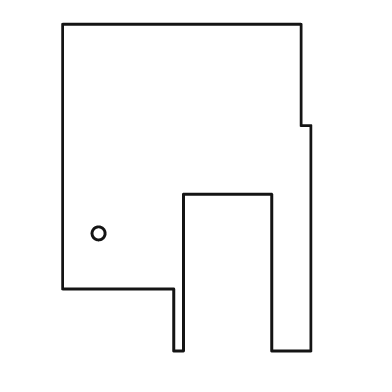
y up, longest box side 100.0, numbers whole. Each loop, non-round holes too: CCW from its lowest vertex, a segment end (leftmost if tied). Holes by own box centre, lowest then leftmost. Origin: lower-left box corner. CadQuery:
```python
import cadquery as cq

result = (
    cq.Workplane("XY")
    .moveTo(34.0, 0.0)
    .lineTo(37.0, 0.0)
    .lineTo(37.0, 48.0)
    .lineTo(64.0, 48.0)
    .lineTo(64.0, 0.0)
    .lineTo(76.0, 0.0)
    .lineTo(76.0, 69.0)
    .lineTo(73.0, 69.0)
    .lineTo(73.0, 100.0)
    .lineTo(0.0, 100.0)
    .lineTo(0.0, 19.0)
    .lineTo(34.0, 19.0)
    .close()
    .moveTo(11.0, 36.0)
    .circle(2.0)
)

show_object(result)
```